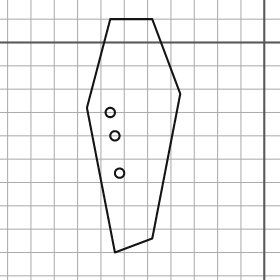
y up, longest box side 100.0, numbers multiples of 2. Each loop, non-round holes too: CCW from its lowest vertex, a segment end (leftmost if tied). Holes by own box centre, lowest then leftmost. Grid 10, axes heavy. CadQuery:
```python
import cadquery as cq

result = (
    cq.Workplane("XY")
    .moveTo(-64.0, -90.0)
    .lineTo(-48.0, -84.0)
    .lineTo(-36.0, -22.0)
    .lineTo(-48.0, 10.0)
    .lineTo(-66.0, 10.0)
    .lineTo(-76.0, -28.0)
    .close()
    .moveTo(-62.0, -56.0)
    .circle(2.0)
    .moveTo(-64.0, -40.0)
    .circle(2.0)
    .moveTo(-66.0, -30.0)
    .circle(2.0)
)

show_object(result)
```